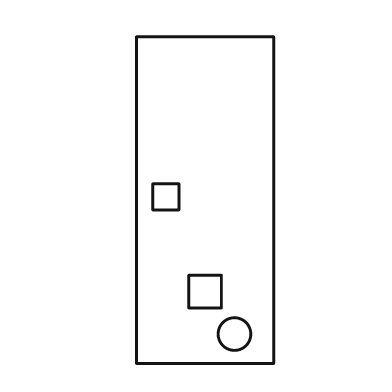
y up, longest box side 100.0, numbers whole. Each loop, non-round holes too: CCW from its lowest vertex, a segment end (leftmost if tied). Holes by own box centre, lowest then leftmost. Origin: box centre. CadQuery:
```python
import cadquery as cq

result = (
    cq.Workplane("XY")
    .moveTo(-21.0, -50.0)
    .lineTo(21.0, -50.0)
    .lineTo(21.0, 50.0)
    .lineTo(-21.0, 50.0)
    .close()
    .moveTo(9.0, -41.0)
    .circle(5.0)
    .moveTo(-5.0, -33.0)
    .lineTo(5.0, -33.0)
    .lineTo(5.0, -23.0)
    .lineTo(-5.0, -23.0)
    .close()
    .moveTo(-16.0, -3.0)
    .lineTo(-8.0, -3.0)
    .lineTo(-8.0, 5.0)
    .lineTo(-16.0, 5.0)
    .close()
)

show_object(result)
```